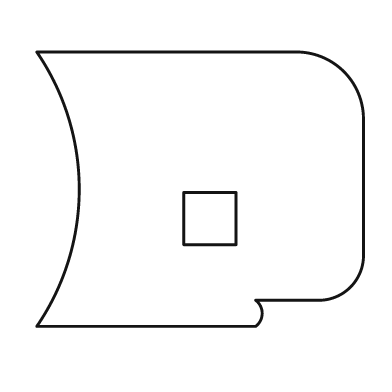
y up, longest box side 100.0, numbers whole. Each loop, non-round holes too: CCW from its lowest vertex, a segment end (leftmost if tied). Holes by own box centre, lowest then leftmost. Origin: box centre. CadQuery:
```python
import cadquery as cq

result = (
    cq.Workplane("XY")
    .moveTo(-50.0, -42.0)
    .lineTo(17.0, -42.0)
    .threePointArc((19.0, -38.0), (17.0, -34.0))
    .lineTo(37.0, -34.0)
    .threePointArc((46.0, -30.0), (50.0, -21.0))
    .lineTo(50.0, 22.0)
    .threePointArc((44.0, 36.0), (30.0, 42.0))
    .lineTo(-50.0, 42.0)
    .threePointArc((-37.0, 0.0), (-50.0, -42.0))
    .close()
    .moveTo(-5.0, -17.0)
    .lineTo(11.0, -17.0)
    .lineTo(11.0, -1.0)
    .lineTo(-5.0, -1.0)
    .close()
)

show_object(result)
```